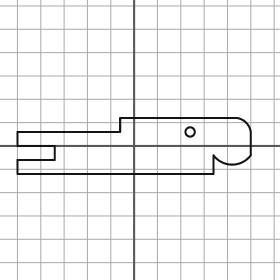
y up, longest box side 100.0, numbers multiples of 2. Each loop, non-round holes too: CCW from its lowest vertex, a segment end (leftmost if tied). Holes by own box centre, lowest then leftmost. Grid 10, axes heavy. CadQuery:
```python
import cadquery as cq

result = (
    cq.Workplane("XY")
    .moveTo(-50.0, -12.0)
    .lineTo(34.0, -12.0)
    .lineTo(34.0, -4.0)
    .threePointArc((42.0, -8.0), (50.0, -4.0))
    .lineTo(50.0, 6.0)
    .threePointArc((48.0, 10.0), (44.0, 12.0))
    .lineTo(-6.0, 12.0)
    .lineTo(-6.0, 6.0)
    .lineTo(-50.0, 6.0)
    .lineTo(-50.0, 0.0)
    .lineTo(-34.0, 0.0)
    .lineTo(-34.0, -6.0)
    .lineTo(-50.0, -6.0)
    .close()
    .moveTo(24.0, 6.0)
    .circle(2.0)
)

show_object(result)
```